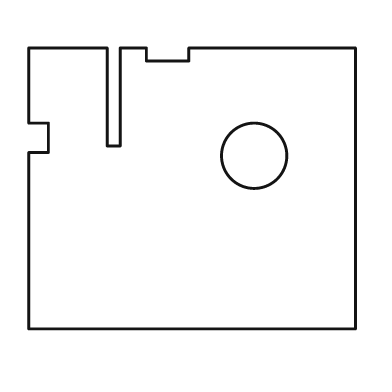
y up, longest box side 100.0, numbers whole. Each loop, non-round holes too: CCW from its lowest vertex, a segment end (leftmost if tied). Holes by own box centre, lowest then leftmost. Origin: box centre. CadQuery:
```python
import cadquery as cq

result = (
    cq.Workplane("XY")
    .moveTo(-50.0, -43.0)
    .lineTo(50.0, -43.0)
    .lineTo(50.0, 43.0)
    .lineTo(-1.0, 43.0)
    .lineTo(-1.0, 39.0)
    .lineTo(-14.0, 39.0)
    .lineTo(-14.0, 43.0)
    .lineTo(-22.0, 43.0)
    .lineTo(-22.0, 13.0)
    .lineTo(-26.0, 13.0)
    .lineTo(-26.0, 43.0)
    .lineTo(-50.0, 43.0)
    .lineTo(-50.0, 20.0)
    .lineTo(-44.0, 20.0)
    .lineTo(-44.0, 11.0)
    .lineTo(-50.0, 11.0)
    .close()
    .moveTo(19.0, 10.0)
    .circle(10.0)
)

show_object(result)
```